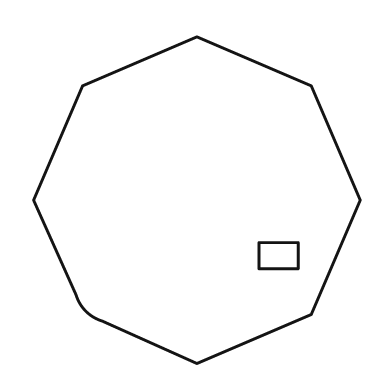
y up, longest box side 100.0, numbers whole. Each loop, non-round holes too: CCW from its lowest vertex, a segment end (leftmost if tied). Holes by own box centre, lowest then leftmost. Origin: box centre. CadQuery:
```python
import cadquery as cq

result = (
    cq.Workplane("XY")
    .moveTo(0.0, -50.0)
    .lineTo(35.0, -35.0)
    .lineTo(50.0, 0.0)
    .lineTo(35.0, 35.0)
    .lineTo(0.0, 50.0)
    .lineTo(-35.0, 35.0)
    .lineTo(-50.0, 0.0)
    .lineTo(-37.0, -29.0)
    .threePointArc((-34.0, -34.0), (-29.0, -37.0))
    .close()
    .moveTo(19.0, -21.0)
    .lineTo(31.0, -21.0)
    .lineTo(31.0, -13.0)
    .lineTo(19.0, -13.0)
    .close()
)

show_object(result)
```